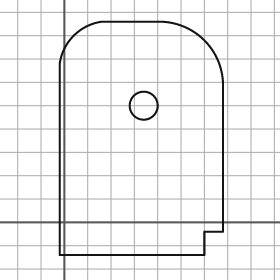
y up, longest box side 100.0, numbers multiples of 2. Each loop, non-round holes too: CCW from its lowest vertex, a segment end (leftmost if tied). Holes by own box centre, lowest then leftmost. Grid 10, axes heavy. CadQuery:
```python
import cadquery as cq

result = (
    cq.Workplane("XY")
    .moveTo(-2.0, -14.0)
    .lineTo(60.0, -14.0)
    .lineTo(60.0, -4.0)
    .lineTo(68.0, -4.0)
    .lineTo(68.0, 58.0)
    .threePointArc((60.0, 78.0), (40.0, 86.0))
    .lineTo(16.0, 86.0)
    .threePointArc((4.0, 80.0), (-2.0, 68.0))
    .close()
    .moveTo(34.0, 50.0)
    .circle(6.0)
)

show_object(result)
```